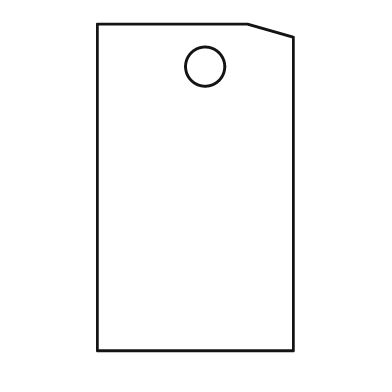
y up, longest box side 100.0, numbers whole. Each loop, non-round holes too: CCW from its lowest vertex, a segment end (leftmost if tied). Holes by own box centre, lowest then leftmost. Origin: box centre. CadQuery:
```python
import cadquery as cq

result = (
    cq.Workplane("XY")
    .moveTo(-30.0, -50.0)
    .lineTo(30.0, -50.0)
    .lineTo(30.0, 46.0)
    .lineTo(16.0, 50.0)
    .lineTo(-30.0, 50.0)
    .close()
    .moveTo(3.0, 37.0)
    .circle(6.0)
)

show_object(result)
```